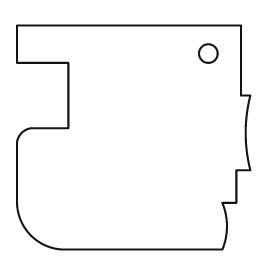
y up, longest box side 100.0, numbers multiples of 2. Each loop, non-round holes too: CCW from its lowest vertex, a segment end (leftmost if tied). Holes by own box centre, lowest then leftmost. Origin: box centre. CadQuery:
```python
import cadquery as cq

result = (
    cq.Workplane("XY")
    .moveTo(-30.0, -48.0)
    .lineTo(38.0, -48.0)
    .threePointArc((40.0, -38.0), (38.0, -28.0))
    .lineTo(44.0, -28.0)
    .lineTo(44.0, -14.0)
    .lineTo(50.0, -14.0)
    .threePointArc((48.0, 2.0), (50.0, 18.0))
    .lineTo(46.0, 18.0)
    .lineTo(46.0, 48.0)
    .lineTo(-50.0, 48.0)
    .lineTo(-50.0, 32.0)
    .lineTo(-28.0, 32.0)
    .lineTo(-28.0, 4.0)
    .lineTo(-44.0, 4.0)
    .threePointArc((-48.0, 2.0), (-50.0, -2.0))
    .lineTo(-50.0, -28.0)
    .threePointArc((-44.0, -42.0), (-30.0, -48.0))
    .close()
    .moveTo(32.0, 36.0)
    .circle(4.0)
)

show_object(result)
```